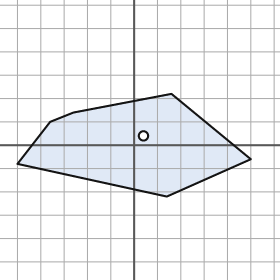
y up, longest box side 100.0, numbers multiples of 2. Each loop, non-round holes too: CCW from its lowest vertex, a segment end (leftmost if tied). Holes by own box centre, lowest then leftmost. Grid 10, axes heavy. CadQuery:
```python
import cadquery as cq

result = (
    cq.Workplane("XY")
    .moveTo(14.0, -22.0)
    .lineTo(50.0, -6.0)
    .lineTo(16.0, 22.0)
    .lineTo(-26.0, 14.0)
    .lineTo(-36.0, 10.0)
    .lineTo(-50.0, -8.0)
    .close()
    .moveTo(4.0, 4.0)
    .circle(2.0)
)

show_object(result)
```